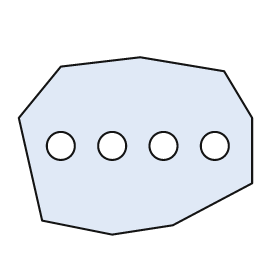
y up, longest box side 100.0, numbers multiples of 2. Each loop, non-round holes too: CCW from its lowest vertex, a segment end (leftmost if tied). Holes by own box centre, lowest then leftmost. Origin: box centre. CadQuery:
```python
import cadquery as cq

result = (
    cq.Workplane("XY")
    .moveTo(-10.0, -38.0)
    .lineTo(16.0, -34.0)
    .lineTo(50.0, -16.0)
    .lineTo(50.0, 12.0)
    .lineTo(38.0, 32.0)
    .lineTo(2.0, 38.0)
    .lineTo(-32.0, 34.0)
    .lineTo(-50.0, 12.0)
    .lineTo(-40.0, -32.0)
    .close()
    .moveTo(-32.0, 0.0)
    .circle(6.0)
    .moveTo(-10.0, 0.0)
    .circle(6.0)
    .moveTo(12.0, 0.0)
    .circle(6.0)
    .moveTo(34.0, 0.0)
    .circle(6.0)
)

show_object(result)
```